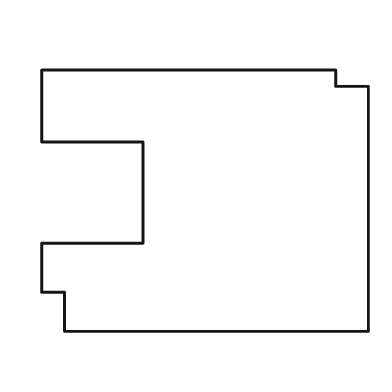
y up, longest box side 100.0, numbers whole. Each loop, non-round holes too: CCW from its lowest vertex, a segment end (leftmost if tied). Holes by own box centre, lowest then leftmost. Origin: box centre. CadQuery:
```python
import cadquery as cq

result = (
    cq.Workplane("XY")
    .moveTo(-43.0, -40.0)
    .lineTo(50.0, -40.0)
    .lineTo(50.0, 35.0)
    .lineTo(40.0, 35.0)
    .lineTo(40.0, 40.0)
    .lineTo(-50.0, 40.0)
    .lineTo(-50.0, 18.0)
    .lineTo(-19.0, 18.0)
    .lineTo(-19.0, -13.0)
    .lineTo(-50.0, -13.0)
    .lineTo(-50.0, -28.0)
    .lineTo(-43.0, -28.0)
    .close()
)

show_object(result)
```